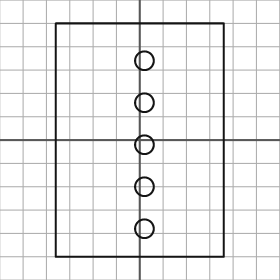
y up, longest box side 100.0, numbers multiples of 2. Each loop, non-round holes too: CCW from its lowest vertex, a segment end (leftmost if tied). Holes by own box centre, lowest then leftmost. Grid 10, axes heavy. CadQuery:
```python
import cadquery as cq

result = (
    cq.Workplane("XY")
    .moveTo(-36.0, -50.0)
    .lineTo(36.0, -50.0)
    .lineTo(36.0, 50.0)
    .lineTo(-36.0, 50.0)
    .close()
    .moveTo(2.0, -38.0)
    .circle(4.0)
    .moveTo(2.0, -20.0)
    .circle(4.0)
    .moveTo(2.0, -2.0)
    .circle(4.0)
    .moveTo(2.0, 16.0)
    .circle(4.0)
    .moveTo(2.0, 34.0)
    .circle(4.0)
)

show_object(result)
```